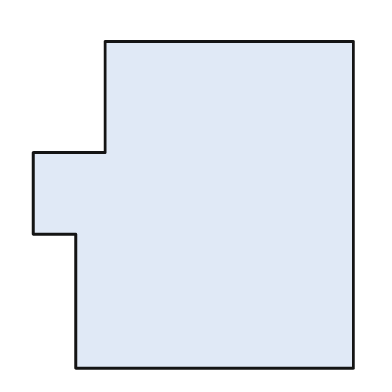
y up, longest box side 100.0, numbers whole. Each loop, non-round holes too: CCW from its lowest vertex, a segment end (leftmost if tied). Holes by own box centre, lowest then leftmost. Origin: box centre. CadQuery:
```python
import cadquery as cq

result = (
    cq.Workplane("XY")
    .moveTo(-36.0, -50.0)
    .lineTo(49.0, -50.0)
    .lineTo(49.0, 50.0)
    .lineTo(-27.0, 50.0)
    .lineTo(-27.0, 16.0)
    .lineTo(-49.0, 16.0)
    .lineTo(-49.0, -9.0)
    .lineTo(-36.0, -9.0)
    .close()
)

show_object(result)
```